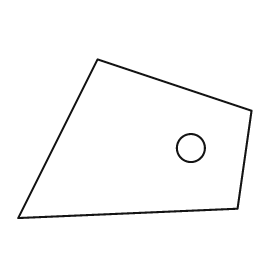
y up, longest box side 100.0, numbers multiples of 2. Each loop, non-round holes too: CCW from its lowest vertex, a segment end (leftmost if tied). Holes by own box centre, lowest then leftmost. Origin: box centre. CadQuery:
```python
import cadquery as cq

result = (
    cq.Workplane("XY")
    .moveTo(-50.0, -34.0)
    .lineTo(44.0, -30.0)
    .lineTo(50.0, 12.0)
    .lineTo(-16.0, 34.0)
    .close()
    .moveTo(24.0, -4.0)
    .circle(6.0)
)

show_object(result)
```